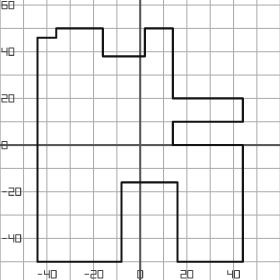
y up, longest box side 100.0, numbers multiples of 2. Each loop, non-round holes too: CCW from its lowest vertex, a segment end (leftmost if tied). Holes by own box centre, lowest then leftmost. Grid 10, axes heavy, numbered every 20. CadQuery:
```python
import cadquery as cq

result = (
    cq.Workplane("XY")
    .moveTo(-44.0, -50.0)
    .lineTo(-8.0, -50.0)
    .lineTo(-8.0, -16.0)
    .lineTo(16.0, -16.0)
    .lineTo(16.0, -50.0)
    .lineTo(44.0, -50.0)
    .lineTo(44.0, 0.0)
    .lineTo(14.0, 0.0)
    .lineTo(14.0, 10.0)
    .lineTo(44.0, 10.0)
    .lineTo(44.0, 20.0)
    .lineTo(14.0, 20.0)
    .lineTo(14.0, 50.0)
    .lineTo(2.0, 50.0)
    .lineTo(2.0, 38.0)
    .lineTo(-16.0, 38.0)
    .lineTo(-16.0, 50.0)
    .lineTo(-36.0, 50.0)
    .lineTo(-36.0, 46.0)
    .lineTo(-44.0, 46.0)
    .close()
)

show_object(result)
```